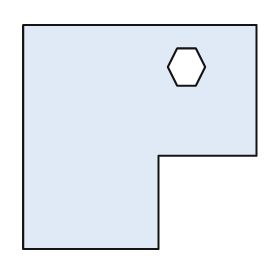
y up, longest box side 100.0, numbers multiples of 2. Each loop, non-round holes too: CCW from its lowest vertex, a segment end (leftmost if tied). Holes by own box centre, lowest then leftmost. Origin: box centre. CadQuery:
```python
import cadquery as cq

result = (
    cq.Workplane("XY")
    .moveTo(-50.0, -48.0)
    .lineTo(8.0, -48.0)
    .lineTo(8.0, -8.0)
    .lineTo(50.0, -8.0)
    .lineTo(50.0, 48.0)
    .lineTo(-50.0, 48.0)
    .close()
    .moveTo(16.0, 22.0)
    .lineTo(24.0, 22.0)
    .lineTo(28.0, 30.0)
    .lineTo(24.0, 38.0)
    .lineTo(16.0, 38.0)
    .lineTo(12.0, 30.0)
    .close()
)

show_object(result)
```